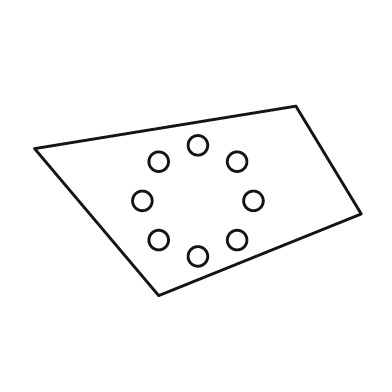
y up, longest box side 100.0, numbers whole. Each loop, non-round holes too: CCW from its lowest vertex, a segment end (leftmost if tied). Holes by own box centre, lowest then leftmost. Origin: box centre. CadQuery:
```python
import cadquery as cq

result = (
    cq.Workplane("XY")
    .moveTo(-12.0, -29.0)
    .lineTo(50.0, -4.0)
    .lineTo(30.0, 29.0)
    .lineTo(-50.0, 16.0)
    .close()
    .moveTo(0.0, -17.0)
    .circle(3.0)
    .moveTo(-12.0, -12.0)
    .circle(3.0)
    .moveTo(12.0, -12.0)
    .circle(3.0)
    .moveTo(-17.0, 0.0)
    .circle(3.0)
    .moveTo(17.0, 0.0)
    .circle(3.0)
    .moveTo(-12.0, 12.0)
    .circle(3.0)
    .moveTo(12.0, 12.0)
    .circle(3.0)
    .moveTo(0.0, 17.0)
    .circle(3.0)
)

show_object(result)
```